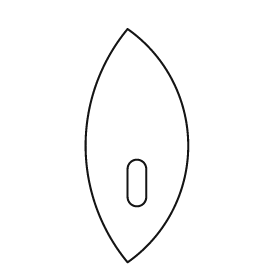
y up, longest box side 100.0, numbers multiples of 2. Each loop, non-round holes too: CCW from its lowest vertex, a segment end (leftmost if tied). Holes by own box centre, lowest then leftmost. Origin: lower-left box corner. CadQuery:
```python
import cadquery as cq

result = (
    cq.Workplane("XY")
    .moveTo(18.0, 0.0)
    .threePointArc((44.0, 50.0), (18.0, 100.0))
    .threePointArc((0.0, 50.0), (18.0, 0.0))
    .close()
    .moveTo(18.0, 28.0)
    .threePointArc((22.0, 24.0), (26.0, 28.0))
    .lineTo(26.0, 40.0)
    .threePointArc((22.0, 44.0), (18.0, 40.0))
    .close()
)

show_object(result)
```